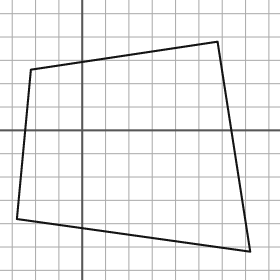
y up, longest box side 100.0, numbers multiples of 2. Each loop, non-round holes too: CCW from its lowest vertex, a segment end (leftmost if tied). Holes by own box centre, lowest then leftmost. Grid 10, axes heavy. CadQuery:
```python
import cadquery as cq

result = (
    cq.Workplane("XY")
    .moveTo(72.0, -52.0)
    .lineTo(58.0, 38.0)
    .lineTo(-22.0, 26.0)
    .lineTo(-28.0, -38.0)
    .close()
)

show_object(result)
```